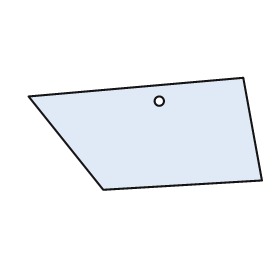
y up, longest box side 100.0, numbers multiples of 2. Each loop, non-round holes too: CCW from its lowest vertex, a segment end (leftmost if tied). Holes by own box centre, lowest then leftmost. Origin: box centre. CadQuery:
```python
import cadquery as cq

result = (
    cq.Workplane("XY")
    .moveTo(-18.0, -24.0)
    .lineTo(50.0, -20.0)
    .lineTo(42.0, 24.0)
    .lineTo(-50.0, 16.0)
    .close()
    .moveTo(6.0, 14.0)
    .circle(2.0)
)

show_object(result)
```